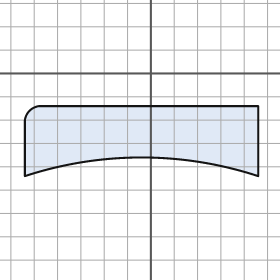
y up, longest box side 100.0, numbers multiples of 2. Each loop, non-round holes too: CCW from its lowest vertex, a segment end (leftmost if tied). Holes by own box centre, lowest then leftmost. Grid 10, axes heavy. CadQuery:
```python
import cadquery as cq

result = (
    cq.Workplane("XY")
    .moveTo(-54.0, -44.0)
    .threePointArc((-4.0, -36.0), (46.0, -44.0))
    .lineTo(46.0, -14.0)
    .lineTo(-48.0, -14.0)
    .threePointArc((-52.0, -16.0), (-54.0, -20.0))
    .close()
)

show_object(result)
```